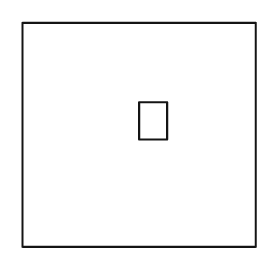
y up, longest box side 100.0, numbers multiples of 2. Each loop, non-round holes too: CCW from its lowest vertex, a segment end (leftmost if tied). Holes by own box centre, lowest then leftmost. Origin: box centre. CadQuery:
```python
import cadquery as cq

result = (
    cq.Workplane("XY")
    .moveTo(-50.0, -48.0)
    .lineTo(50.0, -48.0)
    .lineTo(50.0, 48.0)
    .lineTo(-50.0, 48.0)
    .close()
    .moveTo(0.0, -2.0)
    .lineTo(12.0, -2.0)
    .lineTo(12.0, 14.0)
    .lineTo(0.0, 14.0)
    .close()
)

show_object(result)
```